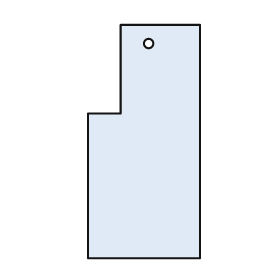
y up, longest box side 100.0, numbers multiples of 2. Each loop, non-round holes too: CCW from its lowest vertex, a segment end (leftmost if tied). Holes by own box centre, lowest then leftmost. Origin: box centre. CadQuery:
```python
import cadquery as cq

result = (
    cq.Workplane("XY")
    .moveTo(-24.0, -50.0)
    .lineTo(24.0, -50.0)
    .lineTo(24.0, 50.0)
    .lineTo(-10.0, 50.0)
    .lineTo(-10.0, 12.0)
    .lineTo(-24.0, 12.0)
    .close()
    .moveTo(2.0, 42.0)
    .circle(2.0)
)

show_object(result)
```